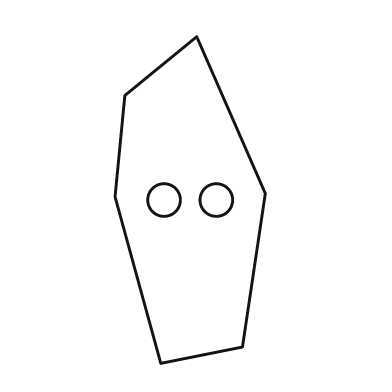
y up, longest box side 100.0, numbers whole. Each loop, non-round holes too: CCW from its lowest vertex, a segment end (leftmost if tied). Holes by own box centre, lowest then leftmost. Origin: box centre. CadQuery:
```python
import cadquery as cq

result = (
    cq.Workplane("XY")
    .moveTo(-9.0, -50.0)
    .lineTo(16.0, -45.0)
    .lineTo(23.0, 2.0)
    .lineTo(2.0, 50.0)
    .lineTo(-20.0, 32.0)
    .lineTo(-23.0, 1.0)
    .close()
    .moveTo(-8.0, 0.0)
    .circle(5.0)
    .moveTo(8.0, 0.0)
    .circle(5.0)
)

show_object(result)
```